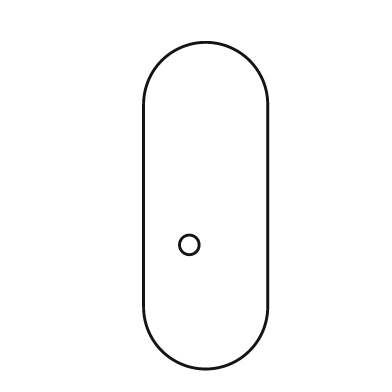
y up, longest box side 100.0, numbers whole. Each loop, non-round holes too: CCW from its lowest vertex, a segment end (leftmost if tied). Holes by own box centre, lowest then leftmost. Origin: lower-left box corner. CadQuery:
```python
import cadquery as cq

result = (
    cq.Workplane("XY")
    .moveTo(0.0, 19.0)
    .threePointArc((19.0, 0.0), (38.0, 19.0))
    .lineTo(38.0, 81.0)
    .threePointArc((19.0, 100.0), (0.0, 81.0))
    .close()
    .moveTo(14.0, 38.0)
    .circle(3.0)
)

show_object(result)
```